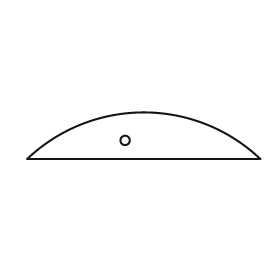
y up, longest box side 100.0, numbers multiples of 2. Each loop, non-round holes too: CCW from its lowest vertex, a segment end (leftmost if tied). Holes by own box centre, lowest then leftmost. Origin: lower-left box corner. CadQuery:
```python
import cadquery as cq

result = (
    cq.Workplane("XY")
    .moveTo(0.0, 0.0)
    .lineTo(100.0, 0.0)
    .threePointArc((50.0, 20.0), (0.0, 0.0))
    .close()
    .moveTo(42.0, 8.0)
    .circle(2.0)
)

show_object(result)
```